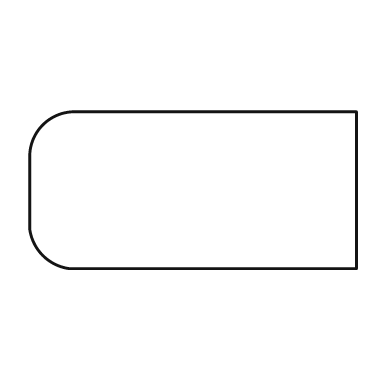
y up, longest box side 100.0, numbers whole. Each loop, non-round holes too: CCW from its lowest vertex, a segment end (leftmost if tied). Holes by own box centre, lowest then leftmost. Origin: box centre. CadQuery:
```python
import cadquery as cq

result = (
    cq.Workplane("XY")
    .moveTo(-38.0, -24.0)
    .lineTo(50.0, -24.0)
    .lineTo(50.0, 24.0)
    .lineTo(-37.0, 24.0)
    .threePointArc((-46.0, 20.0), (-50.0, 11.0))
    .lineTo(-50.0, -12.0)
    .threePointArc((-46.0, -20.0), (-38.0, -24.0))
    .close()
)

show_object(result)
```